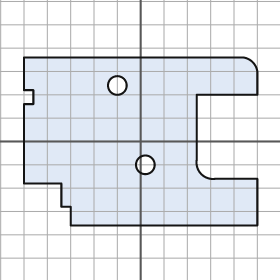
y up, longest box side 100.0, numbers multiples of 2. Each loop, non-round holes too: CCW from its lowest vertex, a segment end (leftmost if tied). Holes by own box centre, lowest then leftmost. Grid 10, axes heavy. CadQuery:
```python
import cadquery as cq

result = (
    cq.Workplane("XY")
    .moveTo(-30.0, -36.0)
    .lineTo(50.0, -36.0)
    .lineTo(50.0, -16.0)
    .lineTo(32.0, -16.0)
    .threePointArc((26.0, -14.0), (24.0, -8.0))
    .lineTo(24.0, 20.0)
    .lineTo(50.0, 20.0)
    .lineTo(50.0, 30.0)
    .threePointArc((48.0, 34.0), (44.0, 36.0))
    .lineTo(-50.0, 36.0)
    .lineTo(-50.0, 22.0)
    .lineTo(-46.0, 22.0)
    .lineTo(-46.0, 16.0)
    .lineTo(-50.0, 16.0)
    .lineTo(-50.0, -18.0)
    .lineTo(-34.0, -18.0)
    .lineTo(-34.0, -28.0)
    .lineTo(-30.0, -28.0)
    .close()
    .moveTo(2.0, -10.0)
    .circle(4.0)
    .moveTo(-10.0, 24.0)
    .circle(4.0)
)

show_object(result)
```